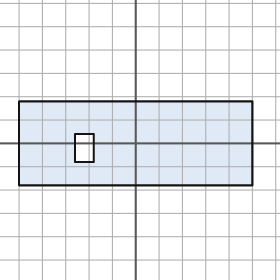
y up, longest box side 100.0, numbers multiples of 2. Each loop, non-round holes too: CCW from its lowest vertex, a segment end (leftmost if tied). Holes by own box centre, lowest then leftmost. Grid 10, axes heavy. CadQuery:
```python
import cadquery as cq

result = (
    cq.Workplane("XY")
    .moveTo(-50.0, -18.0)
    .lineTo(50.0, -18.0)
    .lineTo(50.0, 18.0)
    .lineTo(-50.0, 18.0)
    .close()
    .moveTo(-26.0, -8.0)
    .lineTo(-18.0, -8.0)
    .lineTo(-18.0, 4.0)
    .lineTo(-26.0, 4.0)
    .close()
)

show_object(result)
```